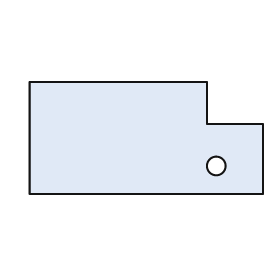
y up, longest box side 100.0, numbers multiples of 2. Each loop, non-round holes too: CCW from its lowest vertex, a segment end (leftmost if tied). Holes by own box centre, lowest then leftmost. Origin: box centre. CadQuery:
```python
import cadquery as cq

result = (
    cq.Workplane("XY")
    .moveTo(-50.0, -24.0)
    .lineTo(50.0, -24.0)
    .lineTo(50.0, 6.0)
    .lineTo(26.0, 6.0)
    .lineTo(26.0, 24.0)
    .lineTo(-50.0, 24.0)
    .close()
    .moveTo(30.0, -12.0)
    .circle(4.0)
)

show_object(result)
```